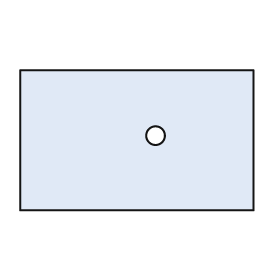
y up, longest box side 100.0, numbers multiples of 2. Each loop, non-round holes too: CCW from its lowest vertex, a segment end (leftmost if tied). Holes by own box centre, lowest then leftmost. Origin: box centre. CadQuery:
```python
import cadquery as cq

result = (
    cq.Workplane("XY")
    .moveTo(-50.0, -30.0)
    .lineTo(50.0, -30.0)
    .lineTo(50.0, 30.0)
    .lineTo(-50.0, 30.0)
    .close()
    .moveTo(8.0, 2.0)
    .circle(4.0)
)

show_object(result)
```